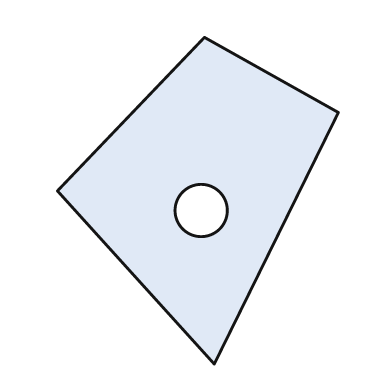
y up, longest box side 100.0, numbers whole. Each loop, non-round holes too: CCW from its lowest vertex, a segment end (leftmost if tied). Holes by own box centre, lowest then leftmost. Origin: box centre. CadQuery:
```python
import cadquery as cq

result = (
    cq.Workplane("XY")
    .moveTo(5.0, -50.0)
    .lineTo(43.0, 27.0)
    .lineTo(2.0, 50.0)
    .lineTo(-43.0, 3.0)
    .close()
    .moveTo(1.0, -3.0)
    .circle(8.0)
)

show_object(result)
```